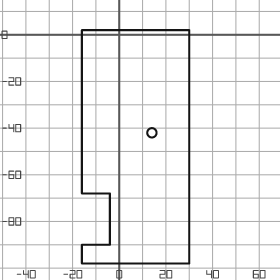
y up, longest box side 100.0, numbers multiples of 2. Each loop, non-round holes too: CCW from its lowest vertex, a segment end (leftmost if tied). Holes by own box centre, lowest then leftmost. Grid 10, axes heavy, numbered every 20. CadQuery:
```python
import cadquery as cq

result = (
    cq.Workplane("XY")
    .moveTo(-16.0, -98.0)
    .lineTo(30.0, -98.0)
    .lineTo(30.0, 2.0)
    .lineTo(-16.0, 2.0)
    .lineTo(-16.0, -68.0)
    .lineTo(-4.0, -68.0)
    .lineTo(-4.0, -90.0)
    .lineTo(-16.0, -90.0)
    .close()
    .moveTo(14.0, -42.0)
    .circle(2.0)
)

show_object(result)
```